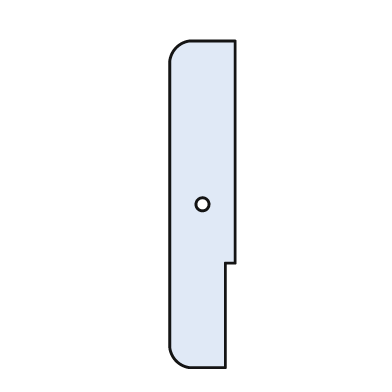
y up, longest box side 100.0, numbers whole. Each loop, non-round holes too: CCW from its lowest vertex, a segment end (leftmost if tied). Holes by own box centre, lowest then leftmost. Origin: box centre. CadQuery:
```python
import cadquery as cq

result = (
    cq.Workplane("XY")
    .moveTo(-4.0, -50.0)
    .lineTo(7.0, -50.0)
    .lineTo(7.0, -18.0)
    .lineTo(10.0, -18.0)
    .lineTo(10.0, 50.0)
    .lineTo(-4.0, 50.0)
    .threePointArc((-8.0, 48.0), (-10.0, 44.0))
    .lineTo(-10.0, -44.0)
    .threePointArc((-8.0, -48.0), (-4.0, -50.0))
    .close()
    .moveTo(0.0, 0.0)
    .circle(2.0)
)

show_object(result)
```